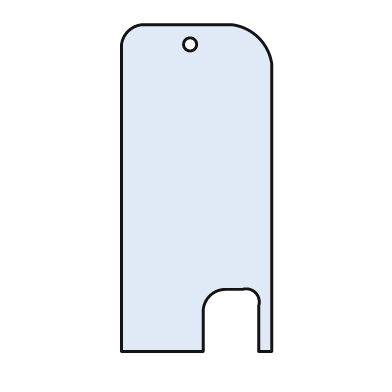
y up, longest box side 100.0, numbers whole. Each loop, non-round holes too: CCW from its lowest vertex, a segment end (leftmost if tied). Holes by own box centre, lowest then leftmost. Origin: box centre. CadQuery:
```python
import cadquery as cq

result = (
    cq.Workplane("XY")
    .moveTo(-23.0, -50.0)
    .lineTo(2.0, -50.0)
    .lineTo(2.0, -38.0)
    .threePointArc((4.0, -33.0), (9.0, -31.0))
    .lineTo(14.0, -31.0)
    .threePointArc((18.0, -32.0), (19.0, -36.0))
    .lineTo(19.0, -50.0)
    .lineTo(23.0, -50.0)
    .lineTo(23.0, 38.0)
    .threePointArc((19.0, 46.0), (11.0, 50.0))
    .lineTo(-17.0, 50.0)
    .threePointArc((-21.0, 48.0), (-23.0, 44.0))
    .close()
    .moveTo(-2.0, 44.0)
    .circle(2.0)
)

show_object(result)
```